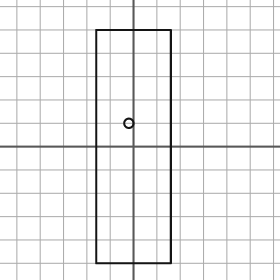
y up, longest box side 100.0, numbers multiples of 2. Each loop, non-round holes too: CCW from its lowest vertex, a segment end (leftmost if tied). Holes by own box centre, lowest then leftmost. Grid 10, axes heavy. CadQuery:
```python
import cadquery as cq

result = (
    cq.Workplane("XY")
    .moveTo(-16.0, -50.0)
    .lineTo(16.0, -50.0)
    .lineTo(16.0, 50.0)
    .lineTo(-16.0, 50.0)
    .close()
    .moveTo(-2.0, 10.0)
    .circle(2.0)
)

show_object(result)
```